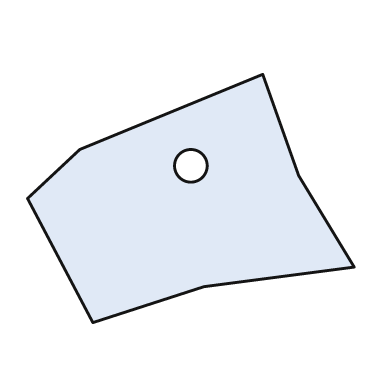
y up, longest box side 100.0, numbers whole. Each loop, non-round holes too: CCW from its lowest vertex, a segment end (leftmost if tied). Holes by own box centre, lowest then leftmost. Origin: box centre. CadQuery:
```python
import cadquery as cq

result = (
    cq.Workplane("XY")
    .moveTo(-30.0, -38.0)
    .lineTo(4.0, -27.0)
    .lineTo(50.0, -21.0)
    .lineTo(33.0, 7.0)
    .lineTo(22.0, 38.0)
    .lineTo(-34.0, 15.0)
    .lineTo(-50.0, 0.0)
    .close()
    .moveTo(0.0, 10.0)
    .circle(5.0)
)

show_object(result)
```